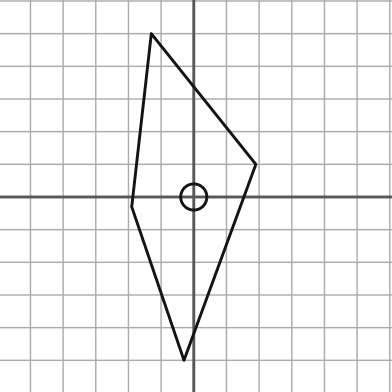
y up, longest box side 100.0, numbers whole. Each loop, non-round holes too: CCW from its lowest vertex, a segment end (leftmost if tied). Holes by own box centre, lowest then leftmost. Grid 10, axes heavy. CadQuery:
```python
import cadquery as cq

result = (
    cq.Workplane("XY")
    .moveTo(-3.0, -50.0)
    .lineTo(19.0, 10.0)
    .lineTo(-13.0, 50.0)
    .lineTo(-19.0, -3.0)
    .close()
    .moveTo(0.0, 0.0)
    .circle(4.0)
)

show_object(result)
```